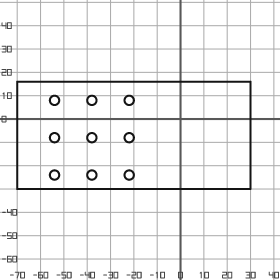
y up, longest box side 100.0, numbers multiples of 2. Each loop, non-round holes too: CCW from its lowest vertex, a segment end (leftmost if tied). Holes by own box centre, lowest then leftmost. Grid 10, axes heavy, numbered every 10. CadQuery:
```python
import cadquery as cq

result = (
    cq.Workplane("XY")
    .moveTo(-70.0, -30.0)
    .lineTo(30.0, -30.0)
    .lineTo(30.0, 16.0)
    .lineTo(-70.0, 16.0)
    .close()
    .moveTo(-54.0, -24.0)
    .circle(2.0)
    .moveTo(-38.0, -24.0)
    .circle(2.0)
    .moveTo(-22.0, -24.0)
    .circle(2.0)
    .moveTo(-54.0, -8.0)
    .circle(2.0)
    .moveTo(-38.0, -8.0)
    .circle(2.0)
    .moveTo(-22.0, -8.0)
    .circle(2.0)
    .moveTo(-54.0, 8.0)
    .circle(2.0)
    .moveTo(-38.0, 8.0)
    .circle(2.0)
    .moveTo(-22.0, 8.0)
    .circle(2.0)
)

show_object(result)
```